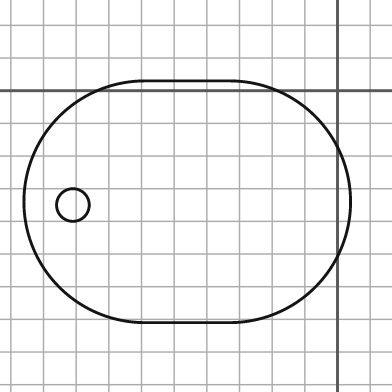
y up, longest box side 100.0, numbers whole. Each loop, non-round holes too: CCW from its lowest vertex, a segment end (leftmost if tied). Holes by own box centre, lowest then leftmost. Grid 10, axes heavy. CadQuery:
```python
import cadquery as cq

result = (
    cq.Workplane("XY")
    .moveTo(-59.0, -71.0)
    .lineTo(-33.0, -71.0)
    .threePointArc((4.0, -34.0), (-33.0, 3.0))
    .lineTo(-59.0, 3.0)
    .threePointArc((-96.0, -34.0), (-59.0, -71.0))
    .close()
    .moveTo(-81.0, -35.0)
    .circle(5.0)
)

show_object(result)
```